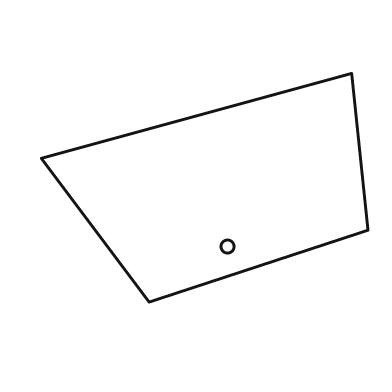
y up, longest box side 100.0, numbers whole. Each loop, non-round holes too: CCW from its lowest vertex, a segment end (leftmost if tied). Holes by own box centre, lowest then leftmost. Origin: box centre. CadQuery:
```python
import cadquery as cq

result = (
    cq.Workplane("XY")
    .moveTo(-17.0, -35.0)
    .lineTo(50.0, -13.0)
    .lineTo(45.0, 35.0)
    .lineTo(-50.0, 9.0)
    .close()
    .moveTo(7.0, -18.0)
    .circle(2.0)
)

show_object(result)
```